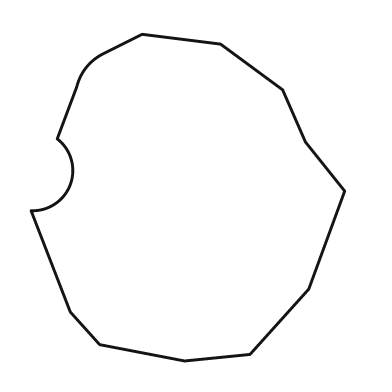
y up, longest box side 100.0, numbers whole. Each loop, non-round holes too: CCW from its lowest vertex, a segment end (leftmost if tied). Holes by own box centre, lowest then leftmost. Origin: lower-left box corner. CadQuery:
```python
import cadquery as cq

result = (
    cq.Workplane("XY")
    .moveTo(47.0, 0.0)
    .lineTo(67.0, 2.0)
    .lineTo(85.0, 22.0)
    .lineTo(96.0, 52.0)
    .lineTo(84.0, 67.0)
    .lineTo(77.0, 83.0)
    .lineTo(58.0, 97.0)
    .lineTo(34.0, 100.0)
    .lineTo(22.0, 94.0)
    .threePointArc((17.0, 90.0), (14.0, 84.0))
    .lineTo(8.0, 68.0)
    .threePointArc((12.0, 54.0), (0.0, 46.0))
    .lineTo(12.0, 15.0)
    .lineTo(21.0, 5.0)
    .close()
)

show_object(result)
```